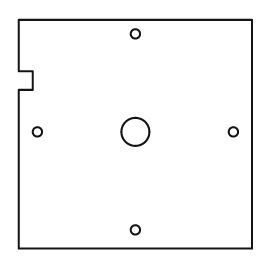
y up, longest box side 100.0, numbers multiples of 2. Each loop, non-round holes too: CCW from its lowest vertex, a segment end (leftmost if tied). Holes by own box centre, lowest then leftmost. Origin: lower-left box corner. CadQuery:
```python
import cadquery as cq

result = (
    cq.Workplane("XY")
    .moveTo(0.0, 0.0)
    .lineTo(100.0, 0.0)
    .lineTo(100.0, 98.0)
    .lineTo(0.0, 98.0)
    .lineTo(0.0, 76.0)
    .lineTo(6.0, 76.0)
    .lineTo(6.0, 68.0)
    .lineTo(0.0, 68.0)
    .close()
    .moveTo(50.0, 8.0)
    .circle(2.0)
    .moveTo(8.0, 50.0)
    .circle(2.0)
    .moveTo(50.0, 50.0)
    .circle(6.0)
    .moveTo(92.0, 50.0)
    .circle(2.0)
    .moveTo(50.0, 92.0)
    .circle(2.0)
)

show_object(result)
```